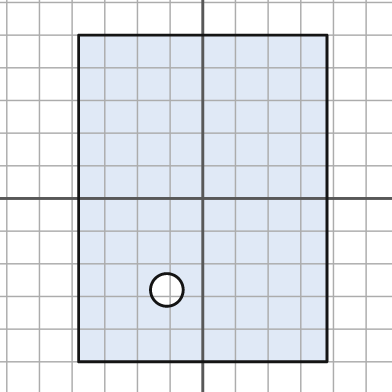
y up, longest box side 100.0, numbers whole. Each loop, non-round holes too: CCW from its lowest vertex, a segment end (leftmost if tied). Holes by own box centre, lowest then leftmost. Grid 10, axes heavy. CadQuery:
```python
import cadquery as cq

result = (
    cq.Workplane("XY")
    .moveTo(-38.0, -50.0)
    .lineTo(38.0, -50.0)
    .lineTo(38.0, 50.0)
    .lineTo(-38.0, 50.0)
    .close()
    .moveTo(-11.0, -28.0)
    .circle(5.0)
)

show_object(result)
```